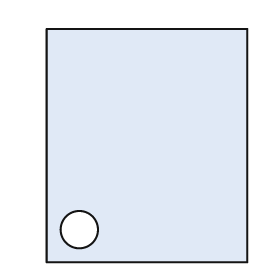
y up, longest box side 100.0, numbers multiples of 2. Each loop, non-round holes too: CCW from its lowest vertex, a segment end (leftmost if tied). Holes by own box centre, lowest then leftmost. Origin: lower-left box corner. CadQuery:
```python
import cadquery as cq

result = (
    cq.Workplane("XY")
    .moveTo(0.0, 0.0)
    .lineTo(86.0, 0.0)
    .lineTo(86.0, 100.0)
    .lineTo(0.0, 100.0)
    .close()
    .moveTo(14.0, 14.0)
    .circle(8.0)
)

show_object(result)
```